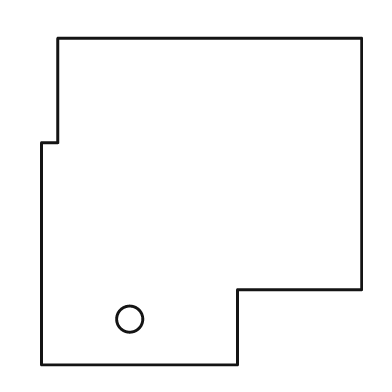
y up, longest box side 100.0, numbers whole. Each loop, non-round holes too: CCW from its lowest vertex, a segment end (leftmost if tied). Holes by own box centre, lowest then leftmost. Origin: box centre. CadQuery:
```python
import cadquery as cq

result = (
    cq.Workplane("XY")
    .moveTo(-49.0, -50.0)
    .lineTo(11.0, -50.0)
    .lineTo(11.0, -27.0)
    .lineTo(49.0, -27.0)
    .lineTo(49.0, 50.0)
    .lineTo(-44.0, 50.0)
    .lineTo(-44.0, 18.0)
    .lineTo(-49.0, 18.0)
    .close()
    .moveTo(-22.0, -36.0)
    .circle(4.0)
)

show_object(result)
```